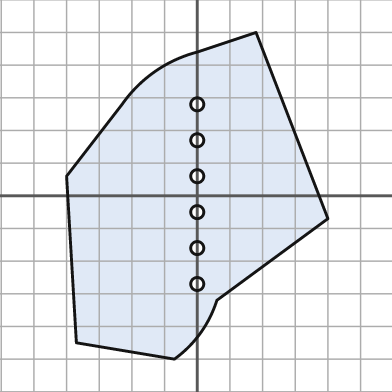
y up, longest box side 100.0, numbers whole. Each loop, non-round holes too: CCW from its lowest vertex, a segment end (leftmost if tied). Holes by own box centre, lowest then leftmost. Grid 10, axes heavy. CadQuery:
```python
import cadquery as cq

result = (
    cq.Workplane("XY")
    .moveTo(-7.0, -50.0)
    .threePointArc((1.0, -42.0), (6.0, -32.0))
    .lineTo(40.0, -7.0)
    .lineTo(18.0, 50.0)
    .lineTo(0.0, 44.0)
    .threePointArc((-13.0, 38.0), (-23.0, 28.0))
    .lineTo(-40.0, 6.0)
    .lineTo(-37.0, -45.0)
    .close()
    .moveTo(0.0, -27.0)
    .circle(2.0)
    .moveTo(0.0, -16.0)
    .circle(2.0)
    .moveTo(0.0, -5.0)
    .circle(2.0)
    .moveTo(0.0, 6.0)
    .circle(2.0)
    .moveTo(0.0, 17.0)
    .circle(2.0)
    .moveTo(0.0, 28.0)
    .circle(2.0)
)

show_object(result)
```